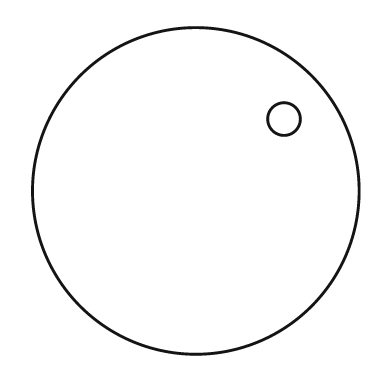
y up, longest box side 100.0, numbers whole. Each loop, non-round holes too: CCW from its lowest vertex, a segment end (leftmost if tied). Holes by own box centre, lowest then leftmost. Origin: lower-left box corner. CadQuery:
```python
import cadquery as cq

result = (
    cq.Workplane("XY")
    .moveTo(50.0, 50.0)
    .circle(50.0)
    .moveTo(77.0, 72.0)
    .circle(5.0)
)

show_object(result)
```